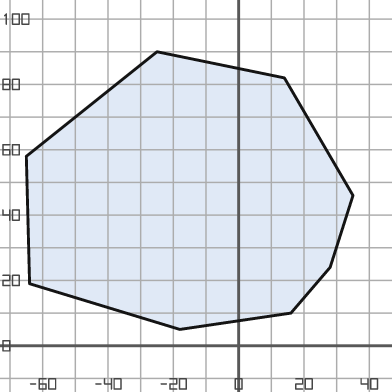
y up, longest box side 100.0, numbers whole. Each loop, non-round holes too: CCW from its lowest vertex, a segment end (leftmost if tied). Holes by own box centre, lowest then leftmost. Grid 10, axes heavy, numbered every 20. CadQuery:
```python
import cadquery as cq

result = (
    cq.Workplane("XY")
    .moveTo(-18.0, 5.0)
    .lineTo(16.0, 10.0)
    .lineTo(28.0, 24.0)
    .lineTo(35.0, 46.0)
    .lineTo(14.0, 82.0)
    .lineTo(-25.0, 90.0)
    .lineTo(-65.0, 58.0)
    .lineTo(-64.0, 19.0)
    .close()
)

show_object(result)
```